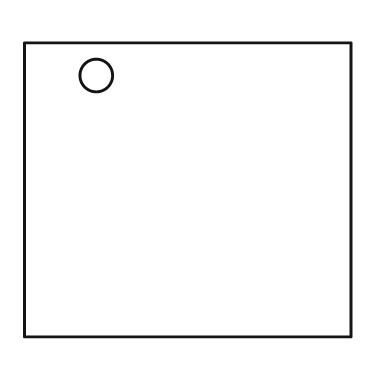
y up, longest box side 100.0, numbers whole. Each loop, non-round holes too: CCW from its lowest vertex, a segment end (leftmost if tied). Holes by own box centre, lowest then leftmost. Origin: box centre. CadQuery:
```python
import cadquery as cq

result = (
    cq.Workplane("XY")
    .moveTo(-50.0, -45.0)
    .lineTo(50.0, -45.0)
    .lineTo(50.0, 45.0)
    .lineTo(-50.0, 45.0)
    .close()
    .moveTo(-28.0, 35.0)
    .circle(5.0)
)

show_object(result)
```